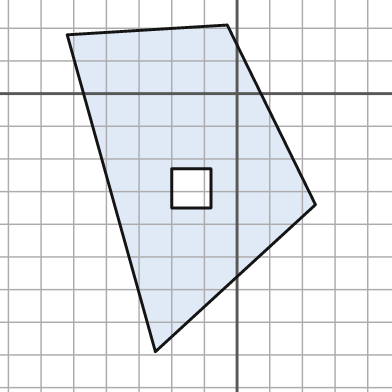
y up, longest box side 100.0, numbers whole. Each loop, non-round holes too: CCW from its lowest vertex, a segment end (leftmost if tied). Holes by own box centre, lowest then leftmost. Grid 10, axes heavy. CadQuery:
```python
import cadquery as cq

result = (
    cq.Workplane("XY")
    .moveTo(-25.0, -79.0)
    .lineTo(24.0, -34.0)
    .lineTo(-3.0, 21.0)
    .lineTo(-52.0, 18.0)
    .close()
    .moveTo(-20.0, -35.0)
    .lineTo(-8.0, -35.0)
    .lineTo(-8.0, -23.0)
    .lineTo(-20.0, -23.0)
    .close()
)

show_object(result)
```